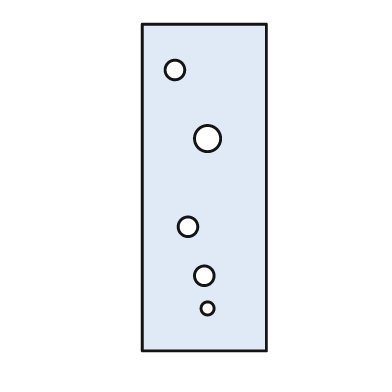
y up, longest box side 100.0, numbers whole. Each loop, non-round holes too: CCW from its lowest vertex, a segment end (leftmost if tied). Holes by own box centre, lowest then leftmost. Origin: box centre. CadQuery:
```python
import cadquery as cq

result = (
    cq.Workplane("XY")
    .moveTo(-19.0, -50.0)
    .lineTo(19.0, -50.0)
    .lineTo(19.0, 50.0)
    .lineTo(-19.0, 50.0)
    .close()
    .moveTo(1.0, -37.0)
    .circle(2.0)
    .moveTo(0.0, -27.0)
    .circle(3.0)
    .moveTo(-5.0, -12.0)
    .circle(3.0)
    .moveTo(1.0, 15.0)
    .circle(4.0)
    .moveTo(-9.0, 36.0)
    .circle(3.0)
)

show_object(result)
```